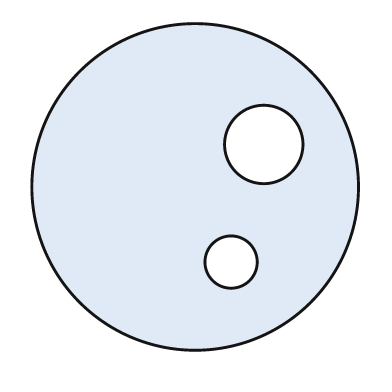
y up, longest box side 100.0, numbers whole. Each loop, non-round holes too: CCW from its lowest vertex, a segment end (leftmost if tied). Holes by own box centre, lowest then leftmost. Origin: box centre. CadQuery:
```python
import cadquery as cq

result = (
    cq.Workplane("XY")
    .moveTo(0.0, 0.0)
    .circle(50.0)
    .moveTo(11.0, -23.0)
    .circle(8.0)
    .moveTo(21.0, 13.0)
    .circle(12.0)
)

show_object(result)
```